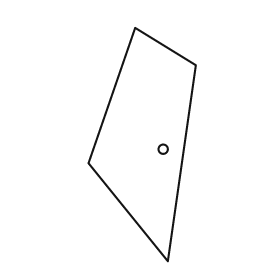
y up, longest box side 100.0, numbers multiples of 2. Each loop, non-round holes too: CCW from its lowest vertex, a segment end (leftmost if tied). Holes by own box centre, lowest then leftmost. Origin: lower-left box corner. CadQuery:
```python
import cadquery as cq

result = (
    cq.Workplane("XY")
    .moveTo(34.0, 0.0)
    .lineTo(46.0, 84.0)
    .lineTo(20.0, 100.0)
    .lineTo(0.0, 42.0)
    .close()
    .moveTo(32.0, 48.0)
    .circle(2.0)
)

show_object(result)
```